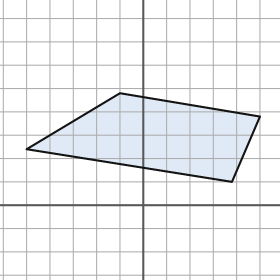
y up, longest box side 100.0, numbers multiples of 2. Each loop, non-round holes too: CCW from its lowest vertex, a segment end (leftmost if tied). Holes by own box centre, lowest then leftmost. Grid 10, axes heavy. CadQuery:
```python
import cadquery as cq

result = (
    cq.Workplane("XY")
    .moveTo(38.0, 10.0)
    .lineTo(50.0, 38.0)
    .lineTo(-10.0, 48.0)
    .lineTo(-50.0, 24.0)
    .close()
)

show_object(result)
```